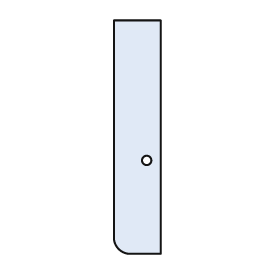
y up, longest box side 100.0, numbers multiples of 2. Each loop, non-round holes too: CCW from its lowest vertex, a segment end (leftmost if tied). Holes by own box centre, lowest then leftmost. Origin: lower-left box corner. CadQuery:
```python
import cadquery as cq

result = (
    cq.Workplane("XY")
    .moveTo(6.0, 0.0)
    .lineTo(20.0, 0.0)
    .lineTo(20.0, 100.0)
    .lineTo(0.0, 100.0)
    .lineTo(0.0, 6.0)
    .threePointArc((2.0, 2.0), (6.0, 0.0))
    .close()
    .moveTo(14.0, 40.0)
    .circle(2.0)
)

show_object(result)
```